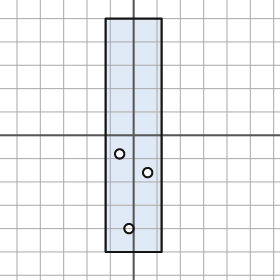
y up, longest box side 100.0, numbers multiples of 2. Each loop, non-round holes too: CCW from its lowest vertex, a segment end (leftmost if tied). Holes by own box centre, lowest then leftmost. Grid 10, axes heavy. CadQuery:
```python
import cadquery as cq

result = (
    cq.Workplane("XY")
    .moveTo(-12.0, -50.0)
    .lineTo(12.0, -50.0)
    .lineTo(12.0, 50.0)
    .lineTo(-12.0, 50.0)
    .close()
    .moveTo(-2.0, -40.0)
    .circle(2.0)
    .moveTo(6.0, -16.0)
    .circle(2.0)
    .moveTo(-6.0, -8.0)
    .circle(2.0)
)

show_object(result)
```